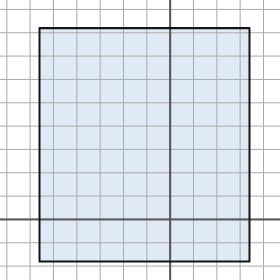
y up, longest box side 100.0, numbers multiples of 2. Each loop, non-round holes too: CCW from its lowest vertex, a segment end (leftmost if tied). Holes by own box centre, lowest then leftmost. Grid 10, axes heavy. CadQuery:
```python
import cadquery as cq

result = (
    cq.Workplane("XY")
    .moveTo(-56.0, -18.0)
    .lineTo(34.0, -18.0)
    .lineTo(34.0, 82.0)
    .lineTo(-56.0, 82.0)
    .close()
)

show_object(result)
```